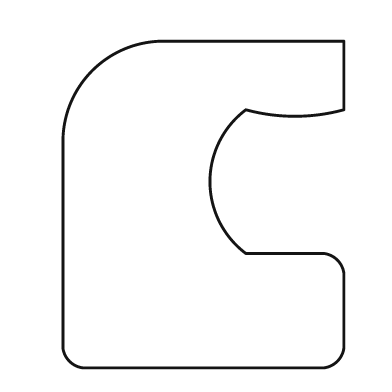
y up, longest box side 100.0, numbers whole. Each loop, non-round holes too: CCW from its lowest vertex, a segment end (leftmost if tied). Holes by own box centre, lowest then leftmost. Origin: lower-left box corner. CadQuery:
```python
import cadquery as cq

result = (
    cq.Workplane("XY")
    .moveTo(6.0, 0.0)
    .lineTo(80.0, 0.0)
    .threePointArc((84.0, 2.0), (86.0, 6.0))
    .lineTo(86.0, 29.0)
    .threePointArc((84.0, 33.0), (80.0, 35.0))
    .lineTo(56.0, 35.0)
    .threePointArc((45.0, 57.0), (56.0, 79.0))
    .threePointArc((71.0, 77.0), (86.0, 79.0))
    .lineTo(86.0, 100.0)
    .lineTo(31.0, 100.0)
    .threePointArc((9.0, 91.0), (0.0, 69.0))
    .lineTo(0.0, 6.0)
    .threePointArc((2.0, 2.0), (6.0, 0.0))
    .close()
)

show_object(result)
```